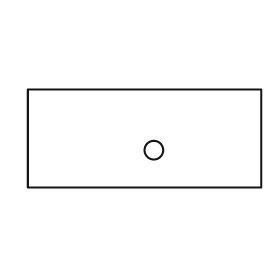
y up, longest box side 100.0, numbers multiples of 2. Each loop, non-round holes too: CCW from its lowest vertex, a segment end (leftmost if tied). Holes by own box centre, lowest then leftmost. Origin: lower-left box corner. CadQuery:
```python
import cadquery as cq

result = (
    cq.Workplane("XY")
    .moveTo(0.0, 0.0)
    .lineTo(100.0, 0.0)
    .lineTo(100.0, 42.0)
    .lineTo(0.0, 42.0)
    .close()
    .moveTo(54.0, 16.0)
    .circle(4.0)
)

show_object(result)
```